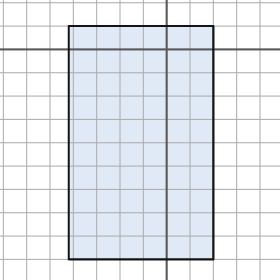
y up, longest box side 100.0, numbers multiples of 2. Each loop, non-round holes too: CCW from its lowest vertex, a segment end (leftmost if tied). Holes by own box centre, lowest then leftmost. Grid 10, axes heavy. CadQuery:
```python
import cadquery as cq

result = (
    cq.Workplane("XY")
    .moveTo(-42.0, -90.0)
    .lineTo(20.0, -90.0)
    .lineTo(20.0, 10.0)
    .lineTo(-42.0, 10.0)
    .close()
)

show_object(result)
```